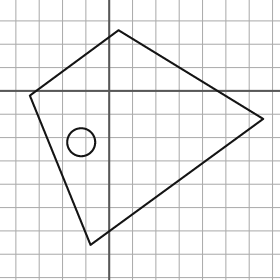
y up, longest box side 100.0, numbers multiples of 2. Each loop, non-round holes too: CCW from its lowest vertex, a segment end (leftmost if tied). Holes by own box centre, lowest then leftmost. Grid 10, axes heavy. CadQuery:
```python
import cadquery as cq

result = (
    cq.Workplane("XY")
    .moveTo(-8.0, -66.0)
    .lineTo(66.0, -12.0)
    .lineTo(4.0, 26.0)
    .lineTo(-34.0, -2.0)
    .close()
    .moveTo(-12.0, -22.0)
    .circle(6.0)
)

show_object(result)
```